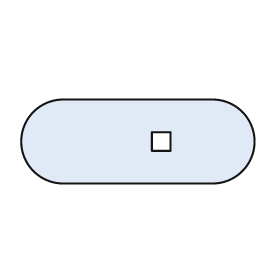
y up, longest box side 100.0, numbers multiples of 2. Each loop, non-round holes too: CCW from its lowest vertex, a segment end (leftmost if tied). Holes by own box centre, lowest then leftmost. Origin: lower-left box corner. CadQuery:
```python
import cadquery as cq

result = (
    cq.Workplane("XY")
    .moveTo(18.0, 0.0)
    .lineTo(82.0, 0.0)
    .threePointArc((100.0, 18.0), (82.0, 36.0))
    .lineTo(18.0, 36.0)
    .threePointArc((0.0, 18.0), (18.0, 0.0))
    .close()
    .moveTo(56.0, 14.0)
    .lineTo(64.0, 14.0)
    .lineTo(64.0, 22.0)
    .lineTo(56.0, 22.0)
    .close()
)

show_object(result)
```